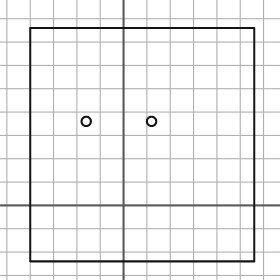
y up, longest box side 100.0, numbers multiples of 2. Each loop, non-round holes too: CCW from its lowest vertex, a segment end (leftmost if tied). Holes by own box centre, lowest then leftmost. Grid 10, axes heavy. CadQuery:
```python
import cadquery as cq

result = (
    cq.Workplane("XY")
    .moveTo(-40.0, -24.0)
    .lineTo(56.0, -24.0)
    .lineTo(56.0, 76.0)
    .lineTo(-40.0, 76.0)
    .close()
    .moveTo(-16.0, 36.0)
    .circle(2.0)
    .moveTo(12.0, 36.0)
    .circle(2.0)
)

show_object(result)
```